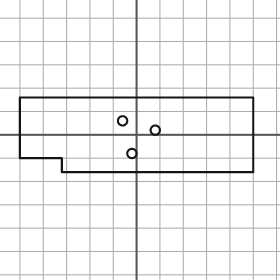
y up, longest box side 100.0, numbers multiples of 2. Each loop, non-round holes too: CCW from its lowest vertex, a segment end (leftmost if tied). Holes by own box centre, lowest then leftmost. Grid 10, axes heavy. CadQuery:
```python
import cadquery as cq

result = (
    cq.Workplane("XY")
    .moveTo(-32.0, -16.0)
    .lineTo(50.0, -16.0)
    .lineTo(50.0, 16.0)
    .lineTo(-50.0, 16.0)
    .lineTo(-50.0, -10.0)
    .lineTo(-32.0, -10.0)
    .close()
    .moveTo(-2.0, -8.0)
    .circle(2.0)
    .moveTo(8.0, 2.0)
    .circle(2.0)
    .moveTo(-6.0, 6.0)
    .circle(2.0)
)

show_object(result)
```